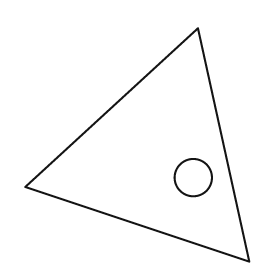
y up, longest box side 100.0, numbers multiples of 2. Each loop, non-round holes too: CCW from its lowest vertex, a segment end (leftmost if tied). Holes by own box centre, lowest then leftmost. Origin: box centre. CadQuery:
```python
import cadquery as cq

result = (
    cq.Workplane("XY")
    .moveTo(48.0, -50.0)
    .lineTo(26.0, 50.0)
    .lineTo(-48.0, -18.0)
    .close()
    .moveTo(24.0, -14.0)
    .circle(8.0)
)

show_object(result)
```